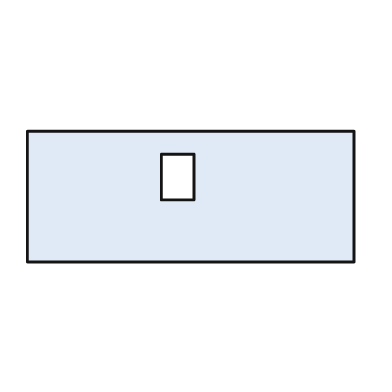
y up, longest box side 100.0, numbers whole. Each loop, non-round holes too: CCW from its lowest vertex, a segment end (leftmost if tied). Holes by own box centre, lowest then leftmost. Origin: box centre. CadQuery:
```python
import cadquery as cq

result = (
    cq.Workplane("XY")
    .moveTo(-50.0, -20.0)
    .lineTo(50.0, -20.0)
    .lineTo(50.0, 20.0)
    .lineTo(-50.0, 20.0)
    .close()
    .moveTo(-9.0, -1.0)
    .lineTo(1.0, -1.0)
    .lineTo(1.0, 13.0)
    .lineTo(-9.0, 13.0)
    .close()
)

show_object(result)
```